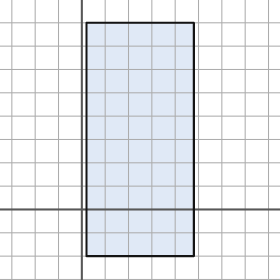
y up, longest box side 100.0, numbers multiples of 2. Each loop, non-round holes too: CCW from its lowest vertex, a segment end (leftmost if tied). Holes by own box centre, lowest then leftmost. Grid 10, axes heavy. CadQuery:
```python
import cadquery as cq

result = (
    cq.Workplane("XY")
    .moveTo(2.0, -20.0)
    .lineTo(48.0, -20.0)
    .lineTo(48.0, 80.0)
    .lineTo(2.0, 80.0)
    .close()
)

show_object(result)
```